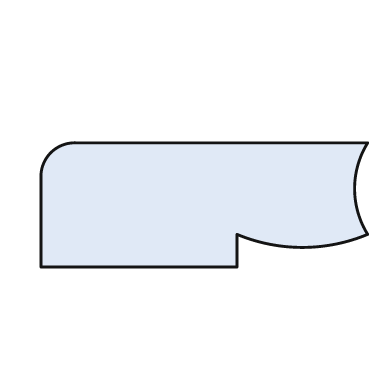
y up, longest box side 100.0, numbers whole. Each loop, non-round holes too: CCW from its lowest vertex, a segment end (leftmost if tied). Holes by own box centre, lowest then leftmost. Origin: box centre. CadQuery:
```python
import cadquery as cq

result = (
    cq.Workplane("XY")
    .moveTo(-50.0, -19.0)
    .lineTo(10.0, -19.0)
    .lineTo(10.0, -9.0)
    .threePointArc((30.0, -13.0), (50.0, -9.0))
    .threePointArc((46.0, 5.0), (50.0, 19.0))
    .lineTo(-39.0, 19.0)
    .threePointArc((-47.0, 16.0), (-50.0, 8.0))
    .close()
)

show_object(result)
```